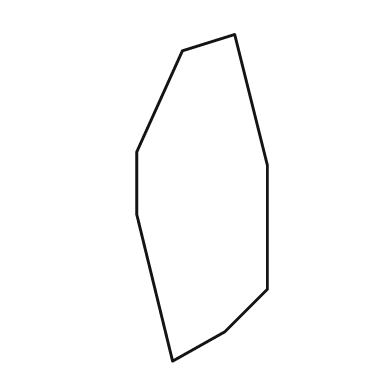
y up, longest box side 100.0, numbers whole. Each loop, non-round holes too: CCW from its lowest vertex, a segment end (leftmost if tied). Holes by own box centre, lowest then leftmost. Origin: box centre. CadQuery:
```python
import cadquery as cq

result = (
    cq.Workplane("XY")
    .moveTo(-9.0, -50.0)
    .lineTo(7.0, -41.0)
    .lineTo(20.0, -28.0)
    .lineTo(20.0, 10.0)
    .lineTo(10.0, 50.0)
    .lineTo(-6.0, 45.0)
    .lineTo(-20.0, 14.0)
    .lineTo(-20.0, -5.0)
    .close()
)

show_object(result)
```